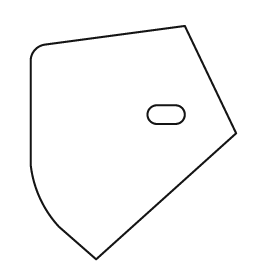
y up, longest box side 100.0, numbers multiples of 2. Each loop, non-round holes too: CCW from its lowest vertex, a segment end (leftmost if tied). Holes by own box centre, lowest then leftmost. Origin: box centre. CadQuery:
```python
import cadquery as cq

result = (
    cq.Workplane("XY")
    .moveTo(-16.0, -50.0)
    .lineTo(44.0, 4.0)
    .lineTo(22.0, 50.0)
    .lineTo(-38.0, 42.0)
    .threePointArc((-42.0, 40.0), (-44.0, 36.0))
    .lineTo(-44.0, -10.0)
    .threePointArc((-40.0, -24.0), (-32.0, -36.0))
    .close()
    .moveTo(10.0, 8.0)
    .lineTo(18.0, 8.0)
    .threePointArc((22.0, 12.0), (18.0, 16.0))
    .lineTo(10.0, 16.0)
    .threePointArc((6.0, 12.0), (10.0, 8.0))
    .close()
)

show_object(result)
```